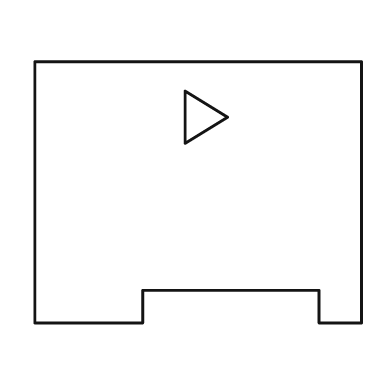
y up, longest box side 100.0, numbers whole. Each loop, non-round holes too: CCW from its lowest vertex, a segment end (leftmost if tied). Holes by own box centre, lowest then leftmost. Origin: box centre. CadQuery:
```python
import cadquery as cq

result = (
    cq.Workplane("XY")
    .moveTo(-50.0, -40.0)
    .lineTo(-17.0, -40.0)
    .lineTo(-17.0, -30.0)
    .lineTo(37.0, -30.0)
    .lineTo(37.0, -40.0)
    .lineTo(50.0, -40.0)
    .lineTo(50.0, 40.0)
    .lineTo(-50.0, 40.0)
    .close()
    .moveTo(-4.0, 15.0)
    .lineTo(9.0, 23.0)
    .lineTo(-4.0, 31.0)
    .close()
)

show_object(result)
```